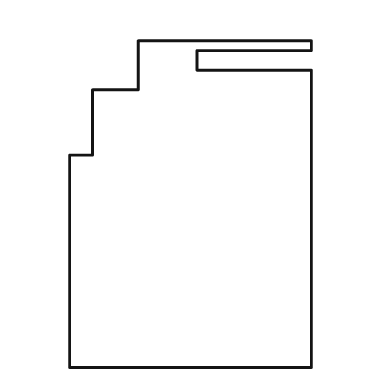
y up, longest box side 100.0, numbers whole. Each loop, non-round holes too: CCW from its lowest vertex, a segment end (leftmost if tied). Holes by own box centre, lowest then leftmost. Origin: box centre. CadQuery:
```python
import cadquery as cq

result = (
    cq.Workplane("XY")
    .moveTo(-37.0, -50.0)
    .lineTo(37.0, -50.0)
    .lineTo(37.0, 41.0)
    .lineTo(2.0, 41.0)
    .lineTo(2.0, 47.0)
    .lineTo(37.0, 47.0)
    .lineTo(37.0, 50.0)
    .lineTo(-16.0, 50.0)
    .lineTo(-16.0, 35.0)
    .lineTo(-30.0, 35.0)
    .lineTo(-30.0, 15.0)
    .lineTo(-37.0, 15.0)
    .close()
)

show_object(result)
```